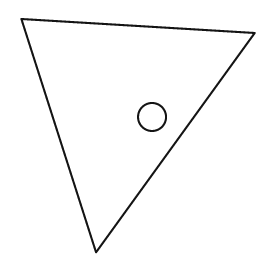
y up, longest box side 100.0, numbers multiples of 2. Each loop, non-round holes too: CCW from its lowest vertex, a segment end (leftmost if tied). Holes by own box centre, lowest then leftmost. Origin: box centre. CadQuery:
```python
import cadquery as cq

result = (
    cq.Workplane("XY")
    .moveTo(-18.0, -50.0)
    .lineTo(50.0, 44.0)
    .lineTo(-50.0, 50.0)
    .close()
    .moveTo(6.0, 8.0)
    .circle(6.0)
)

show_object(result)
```